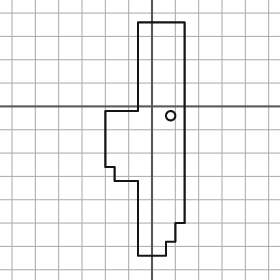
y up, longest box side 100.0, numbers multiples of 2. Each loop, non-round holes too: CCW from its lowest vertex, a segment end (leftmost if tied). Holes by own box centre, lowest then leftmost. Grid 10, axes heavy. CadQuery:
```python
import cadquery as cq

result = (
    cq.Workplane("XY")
    .moveTo(-6.0, -64.0)
    .lineTo(6.0, -64.0)
    .lineTo(6.0, -58.0)
    .lineTo(10.0, -58.0)
    .lineTo(10.0, -50.0)
    .lineTo(14.0, -50.0)
    .lineTo(14.0, 36.0)
    .lineTo(-6.0, 36.0)
    .lineTo(-6.0, -2.0)
    .lineTo(-20.0, -2.0)
    .lineTo(-20.0, -26.0)
    .lineTo(-16.0, -26.0)
    .lineTo(-16.0, -32.0)
    .lineTo(-6.0, -32.0)
    .close()
    .moveTo(8.0, -4.0)
    .circle(2.0)
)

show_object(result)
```